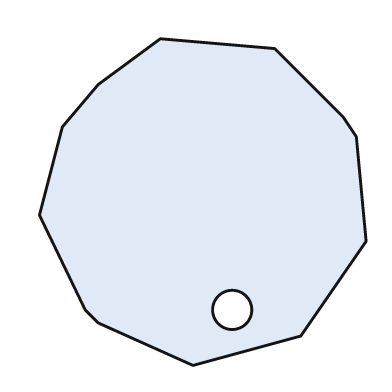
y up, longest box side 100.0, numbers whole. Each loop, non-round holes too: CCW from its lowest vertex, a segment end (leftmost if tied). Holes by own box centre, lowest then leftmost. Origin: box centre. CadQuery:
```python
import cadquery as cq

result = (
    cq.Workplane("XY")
    .moveTo(-3.0, -50.0)
    .lineTo(30.0, -41.0)
    .lineTo(50.0, -12.0)
    .lineTo(47.0, 20.0)
    .lineTo(43.0, 26.0)
    .lineTo(22.0, 47.0)
    .lineTo(-13.0, 50.0)
    .lineTo(-32.0, 36.0)
    .lineTo(-43.0, 23.0)
    .lineTo(-50.0, -4.0)
    .lineTo(-36.0, -33.0)
    .lineTo(-32.0, -37.0)
    .close()
    .moveTo(9.0, -33.0)
    .circle(6.0)
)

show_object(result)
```